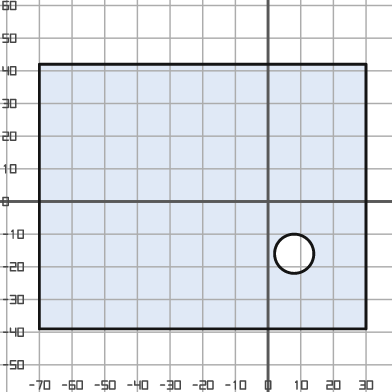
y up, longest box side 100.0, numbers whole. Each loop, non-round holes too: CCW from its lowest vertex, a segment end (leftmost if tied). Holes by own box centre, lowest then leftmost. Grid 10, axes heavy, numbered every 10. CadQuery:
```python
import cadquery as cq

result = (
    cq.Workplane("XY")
    .moveTo(-70.0, -39.0)
    .lineTo(30.0, -39.0)
    .lineTo(30.0, 42.0)
    .lineTo(-70.0, 42.0)
    .close()
    .moveTo(8.0, -16.0)
    .circle(6.0)
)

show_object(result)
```